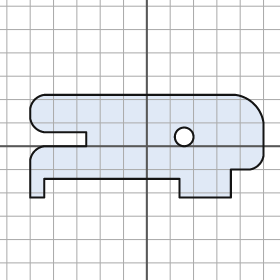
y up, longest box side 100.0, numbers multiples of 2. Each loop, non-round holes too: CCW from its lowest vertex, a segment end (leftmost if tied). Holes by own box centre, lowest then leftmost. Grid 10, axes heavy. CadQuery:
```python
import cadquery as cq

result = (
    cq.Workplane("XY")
    .moveTo(-50.0, -22.0)
    .lineTo(-44.0, -22.0)
    .lineTo(-44.0, -14.0)
    .lineTo(14.0, -14.0)
    .lineTo(14.0, -22.0)
    .lineTo(36.0, -22.0)
    .lineTo(36.0, -10.0)
    .lineTo(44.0, -10.0)
    .threePointArc((48.0, -8.0), (50.0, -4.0))
    .lineTo(50.0, 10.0)
    .threePointArc((46.0, 18.0), (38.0, 22.0))
    .lineTo(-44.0, 22.0)
    .threePointArc((-48.0, 20.0), (-50.0, 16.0))
    .lineTo(-50.0, 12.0)
    .threePointArc((-48.0, 8.0), (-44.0, 6.0))
    .lineTo(-26.0, 6.0)
    .lineTo(-26.0, 0.0)
    .lineTo(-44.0, 0.0)
    .threePointArc((-48.0, -2.0), (-50.0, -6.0))
    .close()
    .moveTo(16.0, 4.0)
    .circle(4.0)
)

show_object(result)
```